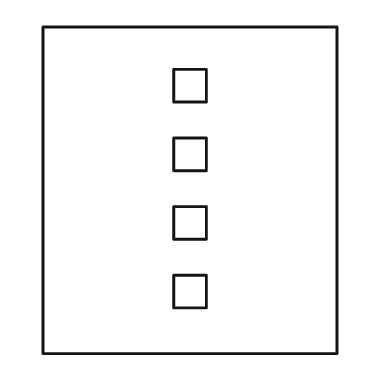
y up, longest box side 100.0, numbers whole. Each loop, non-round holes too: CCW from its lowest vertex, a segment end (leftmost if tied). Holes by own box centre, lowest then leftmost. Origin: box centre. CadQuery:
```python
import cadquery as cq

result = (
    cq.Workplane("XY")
    .moveTo(-45.0, -50.0)
    .lineTo(45.0, -50.0)
    .lineTo(45.0, 50.0)
    .lineTo(-45.0, 50.0)
    .close()
    .moveTo(-5.0, -36.0)
    .lineTo(5.0, -36.0)
    .lineTo(5.0, -26.0)
    .lineTo(-5.0, -26.0)
    .close()
    .moveTo(-5.0, -15.0)
    .lineTo(5.0, -15.0)
    .lineTo(5.0, -5.0)
    .lineTo(-5.0, -5.0)
    .close()
    .moveTo(-5.0, 6.0)
    .lineTo(5.0, 6.0)
    .lineTo(5.0, 16.0)
    .lineTo(-5.0, 16.0)
    .close()
    .moveTo(-5.0, 27.0)
    .lineTo(5.0, 27.0)
    .lineTo(5.0, 37.0)
    .lineTo(-5.0, 37.0)
    .close()
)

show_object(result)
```